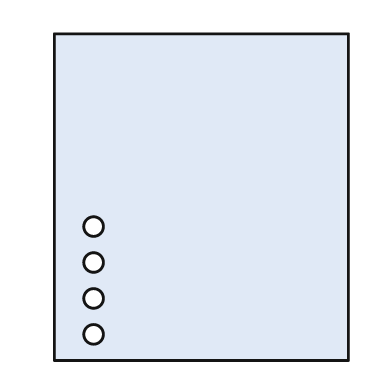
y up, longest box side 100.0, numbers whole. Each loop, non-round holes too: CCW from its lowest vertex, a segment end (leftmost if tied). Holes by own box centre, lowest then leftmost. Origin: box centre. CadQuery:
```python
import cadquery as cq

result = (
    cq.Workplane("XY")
    .moveTo(-45.0, -50.0)
    .lineTo(45.0, -50.0)
    .lineTo(45.0, 50.0)
    .lineTo(-45.0, 50.0)
    .close()
    .moveTo(-33.0, -42.0)
    .circle(3.0)
    .moveTo(-33.0, -31.0)
    .circle(3.0)
    .moveTo(-33.0, -20.0)
    .circle(3.0)
    .moveTo(-33.0, -9.0)
    .circle(3.0)
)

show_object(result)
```